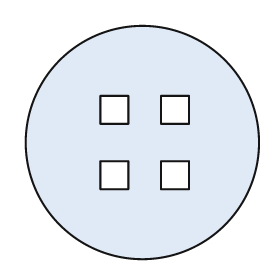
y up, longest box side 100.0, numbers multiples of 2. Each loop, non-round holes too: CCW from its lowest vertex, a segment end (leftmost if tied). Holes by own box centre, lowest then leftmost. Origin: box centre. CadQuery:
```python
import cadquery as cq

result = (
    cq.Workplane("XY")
    .moveTo(0.0, 0.0)
    .circle(50.0)
    .moveTo(-18.0, -20.0)
    .lineTo(-6.0, -20.0)
    .lineTo(-6.0, -8.0)
    .lineTo(-18.0, -8.0)
    .close()
    .moveTo(8.0, -20.0)
    .lineTo(20.0, -20.0)
    .lineTo(20.0, -8.0)
    .lineTo(8.0, -8.0)
    .close()
    .moveTo(-18.0, 8.0)
    .lineTo(-6.0, 8.0)
    .lineTo(-6.0, 20.0)
    .lineTo(-18.0, 20.0)
    .close()
    .moveTo(8.0, 8.0)
    .lineTo(20.0, 8.0)
    .lineTo(20.0, 20.0)
    .lineTo(8.0, 20.0)
    .close()
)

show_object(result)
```